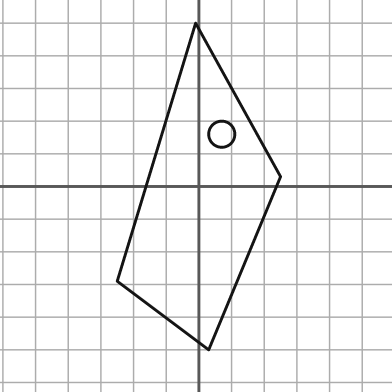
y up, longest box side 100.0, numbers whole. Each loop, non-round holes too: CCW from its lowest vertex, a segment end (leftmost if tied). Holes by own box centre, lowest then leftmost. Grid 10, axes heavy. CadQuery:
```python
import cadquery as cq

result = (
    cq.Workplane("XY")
    .moveTo(3.0, -50.0)
    .lineTo(25.0, 3.0)
    .lineTo(-1.0, 50.0)
    .lineTo(-25.0, -29.0)
    .close()
    .moveTo(7.0, 16.0)
    .circle(4.0)
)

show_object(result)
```